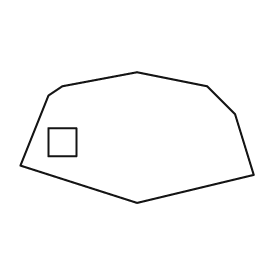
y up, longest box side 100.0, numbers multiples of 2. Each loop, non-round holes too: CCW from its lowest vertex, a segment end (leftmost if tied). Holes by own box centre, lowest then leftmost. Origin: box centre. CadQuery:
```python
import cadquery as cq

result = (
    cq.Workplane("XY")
    .moveTo(0.0, -28.0)
    .lineTo(50.0, -16.0)
    .lineTo(42.0, 10.0)
    .lineTo(30.0, 22.0)
    .lineTo(0.0, 28.0)
    .lineTo(-32.0, 22.0)
    .lineTo(-38.0, 18.0)
    .lineTo(-50.0, -12.0)
    .close()
    .moveTo(-38.0, -8.0)
    .lineTo(-26.0, -8.0)
    .lineTo(-26.0, 4.0)
    .lineTo(-38.0, 4.0)
    .close()
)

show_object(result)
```